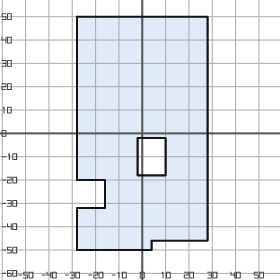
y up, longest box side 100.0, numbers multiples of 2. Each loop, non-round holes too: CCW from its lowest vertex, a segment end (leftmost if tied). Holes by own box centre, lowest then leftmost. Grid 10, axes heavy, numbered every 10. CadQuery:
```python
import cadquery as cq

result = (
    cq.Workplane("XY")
    .moveTo(-28.0, -50.0)
    .lineTo(4.0, -50.0)
    .lineTo(4.0, -46.0)
    .lineTo(28.0, -46.0)
    .lineTo(28.0, 50.0)
    .lineTo(-28.0, 50.0)
    .lineTo(-28.0, -20.0)
    .lineTo(-16.0, -20.0)
    .lineTo(-16.0, -32.0)
    .lineTo(-28.0, -32.0)
    .close()
    .moveTo(-2.0, -18.0)
    .lineTo(10.0, -18.0)
    .lineTo(10.0, -2.0)
    .lineTo(-2.0, -2.0)
    .close()
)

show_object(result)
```